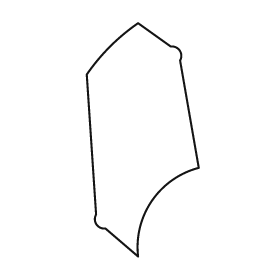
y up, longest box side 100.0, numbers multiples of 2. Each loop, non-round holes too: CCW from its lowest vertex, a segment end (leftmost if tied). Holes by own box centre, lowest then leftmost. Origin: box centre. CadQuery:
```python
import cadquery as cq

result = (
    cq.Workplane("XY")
    .moveTo(-2.0, -50.0)
    .threePointArc((4.0, -26.0), (24.0, -12.0))
    .lineTo(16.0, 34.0)
    .threePointArc((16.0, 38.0), (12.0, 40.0))
    .lineTo(-2.0, 50.0)
    .threePointArc((-14.0, 40.0), (-24.0, 28.0))
    .lineTo(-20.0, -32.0)
    .threePointArc((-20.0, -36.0), (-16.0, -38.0))
    .close()
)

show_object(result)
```